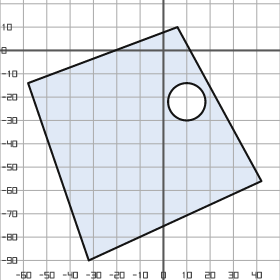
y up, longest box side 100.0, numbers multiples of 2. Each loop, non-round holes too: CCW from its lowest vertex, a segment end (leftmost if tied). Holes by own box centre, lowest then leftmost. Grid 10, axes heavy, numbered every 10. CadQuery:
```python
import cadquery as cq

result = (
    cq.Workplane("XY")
    .moveTo(-32.0, -90.0)
    .lineTo(42.0, -56.0)
    .lineTo(6.0, 10.0)
    .lineTo(-58.0, -14.0)
    .close()
    .moveTo(10.0, -22.0)
    .circle(8.0)
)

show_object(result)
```